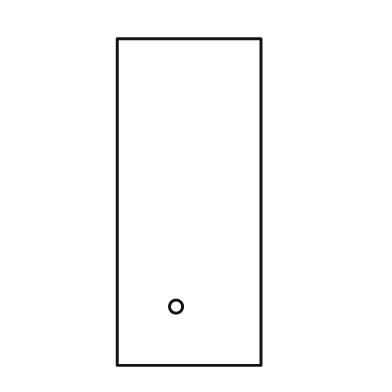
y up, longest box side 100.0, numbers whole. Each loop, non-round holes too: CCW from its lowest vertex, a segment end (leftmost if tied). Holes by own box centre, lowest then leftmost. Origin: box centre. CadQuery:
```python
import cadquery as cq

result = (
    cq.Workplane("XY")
    .moveTo(-22.0, -50.0)
    .lineTo(22.0, -50.0)
    .lineTo(22.0, 50.0)
    .lineTo(-22.0, 50.0)
    .close()
    .moveTo(-4.0, -32.0)
    .circle(2.0)
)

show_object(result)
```